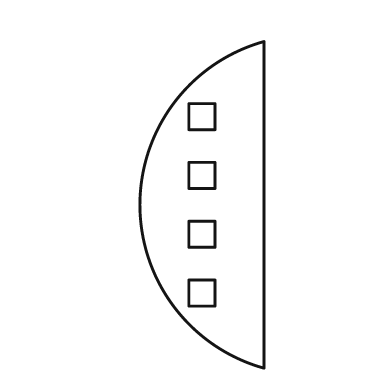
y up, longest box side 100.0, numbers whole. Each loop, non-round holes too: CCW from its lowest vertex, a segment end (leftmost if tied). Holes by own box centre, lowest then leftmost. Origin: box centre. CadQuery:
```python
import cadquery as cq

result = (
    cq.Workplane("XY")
    .moveTo(19.0, -50.0)
    .lineTo(19.0, 50.0)
    .threePointArc((-19.0, 0.0), (19.0, -50.0))
    .close()
    .moveTo(-4.0, -31.0)
    .lineTo(4.0, -31.0)
    .lineTo(4.0, -23.0)
    .lineTo(-4.0, -23.0)
    .close()
    .moveTo(-4.0, -13.0)
    .lineTo(4.0, -13.0)
    .lineTo(4.0, -5.0)
    .lineTo(-4.0, -5.0)
    .close()
    .moveTo(-4.0, 5.0)
    .lineTo(4.0, 5.0)
    .lineTo(4.0, 13.0)
    .lineTo(-4.0, 13.0)
    .close()
    .moveTo(-4.0, 23.0)
    .lineTo(4.0, 23.0)
    .lineTo(4.0, 31.0)
    .lineTo(-4.0, 31.0)
    .close()
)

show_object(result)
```